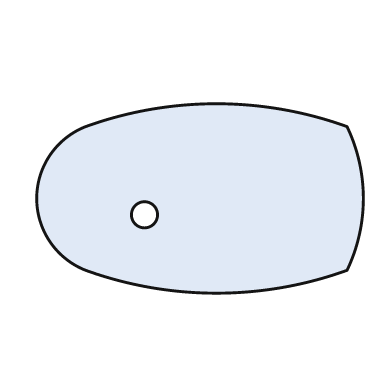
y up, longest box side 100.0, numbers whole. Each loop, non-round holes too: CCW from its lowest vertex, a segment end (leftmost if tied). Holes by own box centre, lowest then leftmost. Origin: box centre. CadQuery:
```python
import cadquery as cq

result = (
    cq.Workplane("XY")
    .moveTo(-35.0, -22.0)
    .threePointArc((5.0, -29.0), (45.0, -22.0))
    .threePointArc((50.0, 0.0), (45.0, 22.0))
    .threePointArc((5.0, 29.0), (-35.0, 22.0))
    .threePointArc((-50.0, 0.0), (-35.0, -22.0))
    .close()
    .moveTo(-17.0, -5.0)
    .circle(4.0)
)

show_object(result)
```